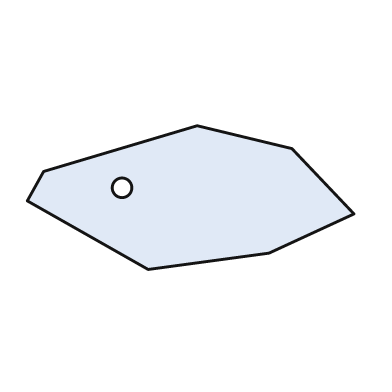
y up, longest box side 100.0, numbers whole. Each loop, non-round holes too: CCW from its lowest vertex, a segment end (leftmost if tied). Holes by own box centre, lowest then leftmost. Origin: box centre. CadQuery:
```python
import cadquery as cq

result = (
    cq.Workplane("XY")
    .moveTo(-13.0, -22.0)
    .lineTo(24.0, -17.0)
    .lineTo(50.0, -5.0)
    .lineTo(31.0, 15.0)
    .lineTo(2.0, 22.0)
    .lineTo(-45.0, 8.0)
    .lineTo(-50.0, -1.0)
    .close()
    .moveTo(-21.0, 3.0)
    .circle(3.0)
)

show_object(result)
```